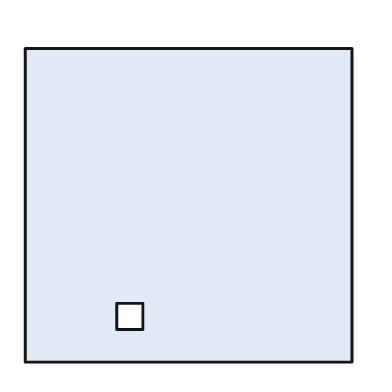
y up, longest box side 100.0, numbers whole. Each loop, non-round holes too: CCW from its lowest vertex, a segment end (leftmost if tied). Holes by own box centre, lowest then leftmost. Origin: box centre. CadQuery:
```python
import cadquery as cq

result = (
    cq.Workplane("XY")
    .moveTo(-50.0, -48.0)
    .lineTo(50.0, -48.0)
    .lineTo(50.0, 48.0)
    .lineTo(-50.0, 48.0)
    .close()
    .moveTo(-22.0, -38.0)
    .lineTo(-14.0, -38.0)
    .lineTo(-14.0, -30.0)
    .lineTo(-22.0, -30.0)
    .close()
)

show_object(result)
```